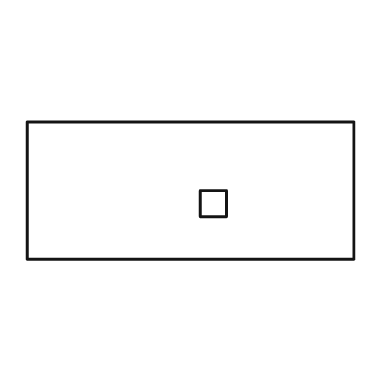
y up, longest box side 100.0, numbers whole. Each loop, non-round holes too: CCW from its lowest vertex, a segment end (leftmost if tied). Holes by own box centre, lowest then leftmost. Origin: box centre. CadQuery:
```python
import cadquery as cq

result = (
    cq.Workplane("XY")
    .moveTo(-50.0, -21.0)
    .lineTo(50.0, -21.0)
    .lineTo(50.0, 21.0)
    .lineTo(-50.0, 21.0)
    .close()
    .moveTo(3.0, -8.0)
    .lineTo(11.0, -8.0)
    .lineTo(11.0, 0.0)
    .lineTo(3.0, 0.0)
    .close()
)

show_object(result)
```